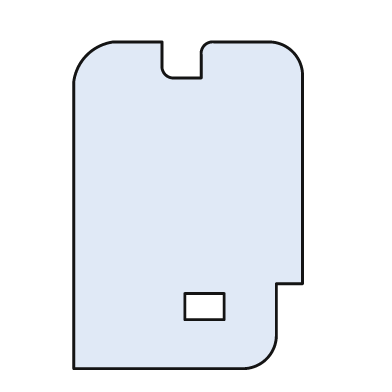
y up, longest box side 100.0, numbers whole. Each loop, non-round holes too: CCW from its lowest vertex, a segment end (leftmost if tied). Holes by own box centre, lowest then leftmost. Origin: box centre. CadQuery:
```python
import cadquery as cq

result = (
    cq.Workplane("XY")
    .moveTo(-35.0, -50.0)
    .lineTo(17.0, -50.0)
    .threePointArc((24.0, -47.0), (27.0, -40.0))
    .lineTo(27.0, -24.0)
    .lineTo(35.0, -24.0)
    .lineTo(35.0, 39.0)
    .threePointArc((32.0, 47.0), (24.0, 50.0))
    .lineTo(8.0, 50.0)
    .threePointArc((5.0, 49.0), (4.0, 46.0))
    .lineTo(4.0, 39.0)
    .lineTo(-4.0, 39.0)
    .threePointArc((-7.0, 40.0), (-8.0, 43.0))
    .lineTo(-8.0, 50.0)
    .lineTo(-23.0, 50.0)
    .threePointArc((-31.0, 46.0), (-35.0, 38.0))
    .close()
    .moveTo(-1.0, -35.0)
    .lineTo(11.0, -35.0)
    .lineTo(11.0, -27.0)
    .lineTo(-1.0, -27.0)
    .close()
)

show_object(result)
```